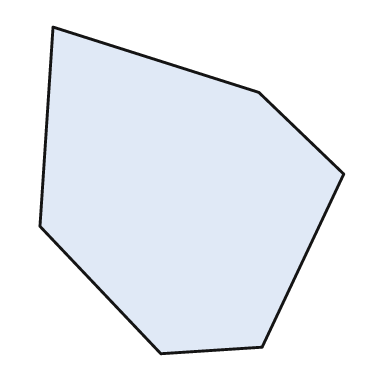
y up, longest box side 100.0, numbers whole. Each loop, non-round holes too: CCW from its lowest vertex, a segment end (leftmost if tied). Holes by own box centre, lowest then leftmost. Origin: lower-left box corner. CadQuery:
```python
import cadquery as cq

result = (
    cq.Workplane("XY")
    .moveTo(37.0, 0.0)
    .lineTo(68.0, 2.0)
    .lineTo(93.0, 55.0)
    .lineTo(67.0, 80.0)
    .lineTo(4.0, 100.0)
    .lineTo(0.0, 39.0)
    .close()
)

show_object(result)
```